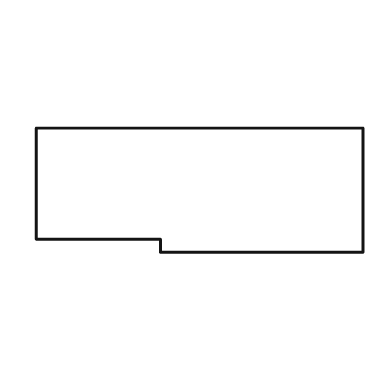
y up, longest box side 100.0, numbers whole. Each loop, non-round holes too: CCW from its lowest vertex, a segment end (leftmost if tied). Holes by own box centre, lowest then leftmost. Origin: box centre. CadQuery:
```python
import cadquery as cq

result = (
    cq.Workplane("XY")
    .moveTo(-12.0, -19.0)
    .lineTo(50.0, -19.0)
    .lineTo(50.0, 19.0)
    .lineTo(-50.0, 19.0)
    .lineTo(-50.0, -15.0)
    .lineTo(-12.0, -15.0)
    .close()
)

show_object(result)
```